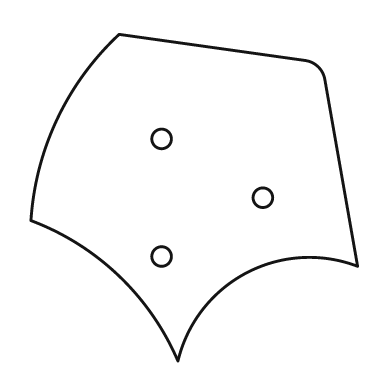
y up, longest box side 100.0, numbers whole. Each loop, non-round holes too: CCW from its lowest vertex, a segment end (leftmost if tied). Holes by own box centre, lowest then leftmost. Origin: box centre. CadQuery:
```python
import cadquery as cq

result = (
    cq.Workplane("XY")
    .moveTo(-5.0, -50.0)
    .threePointArc((16.0, -23.0), (50.0, -21.0))
    .lineTo(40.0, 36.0)
    .threePointArc((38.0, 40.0), (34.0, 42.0))
    .lineTo(-23.0, 50.0)
    .threePointArc((-42.0, 24.0), (-50.0, -7.0))
    .threePointArc((-23.0, -24.0), (-5.0, -50.0))
    .close()
    .moveTo(-10.0, -18.0)
    .circle(3.0)
    .moveTo(21.0, 0.0)
    .circle(3.0)
    .moveTo(-10.0, 18.0)
    .circle(3.0)
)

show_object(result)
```